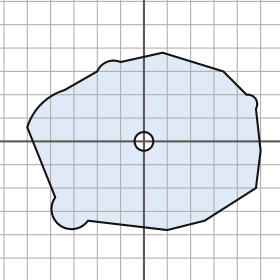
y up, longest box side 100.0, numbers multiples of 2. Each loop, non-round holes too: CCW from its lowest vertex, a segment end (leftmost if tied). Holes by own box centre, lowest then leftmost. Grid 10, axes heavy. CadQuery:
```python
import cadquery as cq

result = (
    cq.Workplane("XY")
    .moveTo(10.0, -38.0)
    .lineTo(26.0, -34.0)
    .lineTo(48.0, -20.0)
    .lineTo(50.0, -4.0)
    .lineTo(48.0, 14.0)
    .threePointArc((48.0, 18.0), (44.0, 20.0))
    .lineTo(34.0, 30.0)
    .lineTo(8.0, 38.0)
    .lineTo(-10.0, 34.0)
    .threePointArc((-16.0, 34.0), (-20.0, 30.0))
    .lineTo(-34.0, 22.0)
    .threePointArc((-44.0, 16.0), (-50.0, 6.0))
    .lineTo(-38.0, -24.0)
    .threePointArc((-36.0, -36.0), (-24.0, -34.0))
    .close()
    .moveTo(0.0, 0.0)
    .circle(4.0)
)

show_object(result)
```